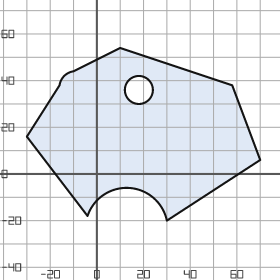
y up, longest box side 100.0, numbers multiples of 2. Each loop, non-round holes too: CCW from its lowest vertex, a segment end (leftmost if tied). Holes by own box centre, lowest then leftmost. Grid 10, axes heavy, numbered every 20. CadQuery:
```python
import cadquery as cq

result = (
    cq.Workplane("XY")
    .moveTo(30.0, -20.0)
    .lineTo(70.0, 6.0)
    .lineTo(58.0, 38.0)
    .lineTo(10.0, 54.0)
    .lineTo(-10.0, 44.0)
    .threePointArc((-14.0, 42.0), (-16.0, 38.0))
    .lineTo(-30.0, 16.0)
    .lineTo(-4.0, -18.0)
    .threePointArc((14.0, -6.0), (30.0, -20.0))
    .close()
    .moveTo(18.0, 36.0)
    .circle(6.0)
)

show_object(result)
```